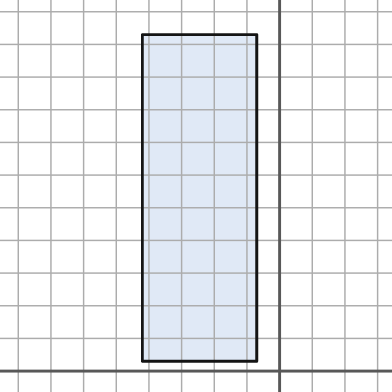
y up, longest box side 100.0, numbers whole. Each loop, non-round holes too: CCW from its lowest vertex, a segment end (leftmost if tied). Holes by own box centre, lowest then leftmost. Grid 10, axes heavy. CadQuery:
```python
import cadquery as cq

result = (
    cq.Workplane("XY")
    .moveTo(-42.0, 3.0)
    .lineTo(-7.0, 3.0)
    .lineTo(-7.0, 103.0)
    .lineTo(-42.0, 103.0)
    .close()
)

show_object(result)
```